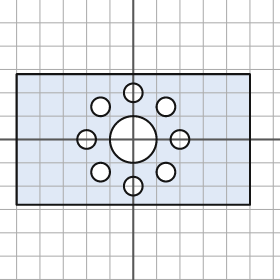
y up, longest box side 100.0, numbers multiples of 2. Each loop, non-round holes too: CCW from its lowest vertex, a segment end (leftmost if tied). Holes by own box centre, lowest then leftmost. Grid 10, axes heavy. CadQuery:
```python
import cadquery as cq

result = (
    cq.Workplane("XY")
    .moveTo(-50.0, -28.0)
    .lineTo(50.0, -28.0)
    .lineTo(50.0, 28.0)
    .lineTo(-50.0, 28.0)
    .close()
    .moveTo(0.0, -20.0)
    .circle(4.0)
    .moveTo(-14.0, -14.0)
    .circle(4.0)
    .moveTo(14.0, -14.0)
    .circle(4.0)
    .moveTo(-20.0, 0.0)
    .circle(4.0)
    .moveTo(0.0, 0.0)
    .circle(10.0)
    .moveTo(20.0, 0.0)
    .circle(4.0)
    .moveTo(-14.0, 14.0)
    .circle(4.0)
    .moveTo(14.0, 14.0)
    .circle(4.0)
    .moveTo(0.0, 20.0)
    .circle(4.0)
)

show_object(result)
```